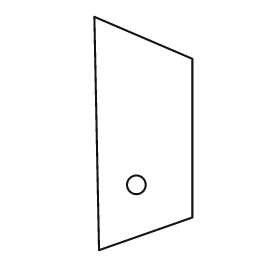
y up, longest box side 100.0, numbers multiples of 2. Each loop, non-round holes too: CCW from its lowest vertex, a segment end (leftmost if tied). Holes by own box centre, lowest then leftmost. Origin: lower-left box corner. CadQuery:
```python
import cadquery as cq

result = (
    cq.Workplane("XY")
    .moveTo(2.0, 0.0)
    .lineTo(42.0, 14.0)
    .lineTo(42.0, 82.0)
    .lineTo(0.0, 100.0)
    .close()
    .moveTo(18.0, 28.0)
    .circle(4.0)
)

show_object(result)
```